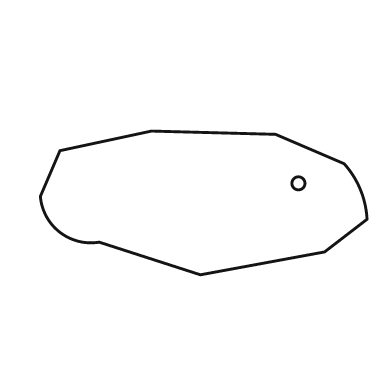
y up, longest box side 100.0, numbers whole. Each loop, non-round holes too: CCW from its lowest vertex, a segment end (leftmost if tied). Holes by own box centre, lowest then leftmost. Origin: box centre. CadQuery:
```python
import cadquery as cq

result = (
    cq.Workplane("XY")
    .moveTo(-1.0, -22.0)
    .lineTo(37.0, -15.0)
    .lineTo(50.0, -5.0)
    .threePointArc((48.0, 4.0), (43.0, 12.0))
    .lineTo(22.0, 21.0)
    .lineTo(-16.0, 22.0)
    .lineTo(-44.0, 16.0)
    .lineTo(-50.0, 2.0)
    .threePointArc((-44.0, -9.0), (-32.0, -12.0))
    .close()
    .moveTo(29.0, 6.0)
    .circle(2.0)
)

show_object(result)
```